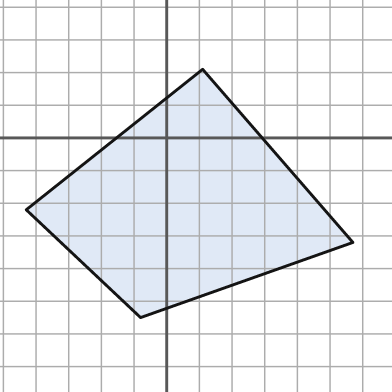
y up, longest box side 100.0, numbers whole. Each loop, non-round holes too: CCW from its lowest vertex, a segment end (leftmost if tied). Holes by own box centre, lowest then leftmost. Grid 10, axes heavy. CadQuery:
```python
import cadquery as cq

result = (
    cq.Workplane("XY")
    .moveTo(-8.0, -55.0)
    .lineTo(57.0, -32.0)
    .lineTo(11.0, 21.0)
    .lineTo(-43.0, -22.0)
    .close()
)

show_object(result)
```